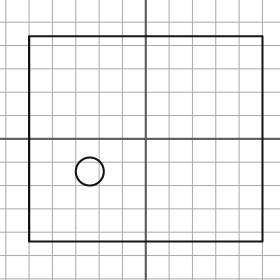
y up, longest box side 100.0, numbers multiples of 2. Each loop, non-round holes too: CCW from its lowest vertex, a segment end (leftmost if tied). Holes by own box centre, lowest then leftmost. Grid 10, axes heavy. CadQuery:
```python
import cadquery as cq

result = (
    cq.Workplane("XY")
    .moveTo(-50.0, -44.0)
    .lineTo(50.0, -44.0)
    .lineTo(50.0, 44.0)
    .lineTo(-50.0, 44.0)
    .close()
    .moveTo(-24.0, -14.0)
    .circle(6.0)
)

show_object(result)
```